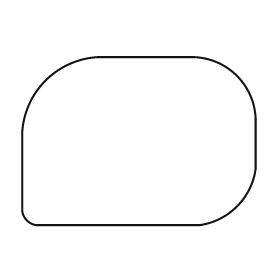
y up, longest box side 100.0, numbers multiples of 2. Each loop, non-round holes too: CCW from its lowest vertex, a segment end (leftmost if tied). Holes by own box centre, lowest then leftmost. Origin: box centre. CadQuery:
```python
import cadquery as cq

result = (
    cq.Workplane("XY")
    .moveTo(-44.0, -36.0)
    .lineTo(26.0, -36.0)
    .threePointArc((42.0, -28.0), (50.0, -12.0))
    .lineTo(50.0, 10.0)
    .threePointArc((42.0, 28.0), (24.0, 36.0))
    .lineTo(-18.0, 36.0)
    .threePointArc((-40.0, 26.0), (-50.0, 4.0))
    .lineTo(-50.0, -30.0)
    .threePointArc((-48.0, -34.0), (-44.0, -36.0))
    .close()
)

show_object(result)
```